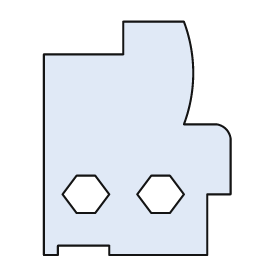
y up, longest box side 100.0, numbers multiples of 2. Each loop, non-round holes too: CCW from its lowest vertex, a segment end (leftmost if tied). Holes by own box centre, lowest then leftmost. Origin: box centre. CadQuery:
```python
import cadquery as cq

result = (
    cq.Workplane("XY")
    .moveTo(-40.0, -50.0)
    .lineTo(-34.0, -50.0)
    .lineTo(-34.0, -46.0)
    .lineTo(-12.0, -46.0)
    .lineTo(-12.0, -50.0)
    .lineTo(30.0, -50.0)
    .lineTo(30.0, -24.0)
    .lineTo(40.0, -24.0)
    .lineTo(40.0, 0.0)
    .threePointArc((38.0, 4.0), (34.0, 6.0))
    .lineTo(20.0, 6.0)
    .threePointArc((24.0, 28.0), (20.0, 50.0))
    .lineTo(-6.0, 50.0)
    .lineTo(-6.0, 36.0)
    .lineTo(-40.0, 36.0)
    .close()
    .moveTo(-26.0, -32.0)
    .lineTo(-18.0, -32.0)
    .lineTo(-12.0, -24.0)
    .lineTo(-18.0, -16.0)
    .lineTo(-26.0, -16.0)
    .lineTo(-32.0, -24.0)
    .close()
    .moveTo(6.0, -32.0)
    .lineTo(14.0, -32.0)
    .lineTo(20.0, -24.0)
    .lineTo(14.0, -16.0)
    .lineTo(6.0, -16.0)
    .lineTo(0.0, -24.0)
    .close()
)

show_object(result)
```